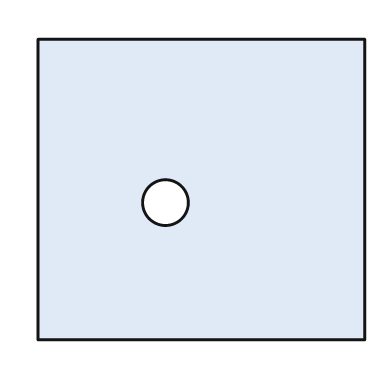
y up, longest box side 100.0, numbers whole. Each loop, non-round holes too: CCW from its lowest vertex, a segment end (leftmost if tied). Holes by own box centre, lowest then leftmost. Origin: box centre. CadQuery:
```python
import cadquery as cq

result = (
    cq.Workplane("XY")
    .moveTo(-50.0, -46.0)
    .lineTo(50.0, -46.0)
    .lineTo(50.0, 46.0)
    .lineTo(-50.0, 46.0)
    .close()
    .moveTo(-11.0, -4.0)
    .circle(7.0)
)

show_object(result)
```